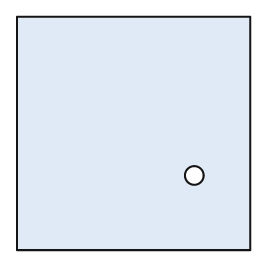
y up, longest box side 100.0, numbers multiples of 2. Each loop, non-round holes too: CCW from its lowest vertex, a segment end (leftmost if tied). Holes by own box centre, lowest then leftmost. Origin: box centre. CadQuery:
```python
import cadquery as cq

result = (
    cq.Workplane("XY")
    .moveTo(-50.0, -50.0)
    .lineTo(50.0, -50.0)
    .lineTo(50.0, 50.0)
    .lineTo(-50.0, 50.0)
    .close()
    .moveTo(26.0, -18.0)
    .circle(4.0)
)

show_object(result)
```